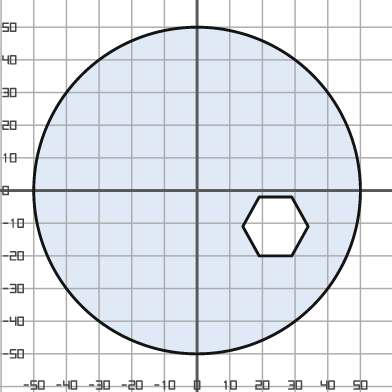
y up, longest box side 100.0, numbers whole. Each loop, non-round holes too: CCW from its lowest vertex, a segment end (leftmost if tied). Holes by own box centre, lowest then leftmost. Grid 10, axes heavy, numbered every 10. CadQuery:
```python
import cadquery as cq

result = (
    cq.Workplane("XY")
    .moveTo(0.0, 0.0)
    .circle(50.0)
    .moveTo(19.0, -20.0)
    .lineTo(29.0, -20.0)
    .lineTo(34.0, -11.0)
    .lineTo(29.0, -2.0)
    .lineTo(19.0, -2.0)
    .lineTo(14.0, -11.0)
    .close()
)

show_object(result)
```